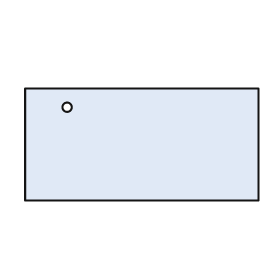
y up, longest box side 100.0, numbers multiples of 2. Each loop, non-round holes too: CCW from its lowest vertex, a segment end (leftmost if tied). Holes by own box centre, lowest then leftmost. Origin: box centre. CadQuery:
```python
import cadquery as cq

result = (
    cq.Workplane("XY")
    .moveTo(-50.0, -24.0)
    .lineTo(50.0, -24.0)
    .lineTo(50.0, 24.0)
    .lineTo(-50.0, 24.0)
    .close()
    .moveTo(-32.0, 16.0)
    .circle(2.0)
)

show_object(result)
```